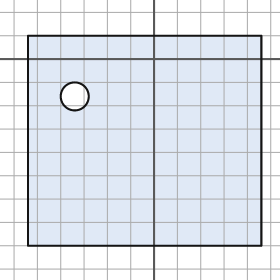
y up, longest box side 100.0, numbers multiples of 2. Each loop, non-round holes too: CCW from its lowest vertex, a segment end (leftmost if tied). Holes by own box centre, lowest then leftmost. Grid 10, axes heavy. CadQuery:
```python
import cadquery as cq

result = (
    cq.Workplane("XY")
    .moveTo(-54.0, -80.0)
    .lineTo(46.0, -80.0)
    .lineTo(46.0, 10.0)
    .lineTo(-54.0, 10.0)
    .close()
    .moveTo(-34.0, -16.0)
    .circle(6.0)
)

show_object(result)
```